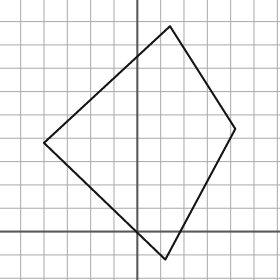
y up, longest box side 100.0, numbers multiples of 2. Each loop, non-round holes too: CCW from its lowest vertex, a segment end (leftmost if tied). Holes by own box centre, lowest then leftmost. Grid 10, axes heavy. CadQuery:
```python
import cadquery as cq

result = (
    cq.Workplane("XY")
    .moveTo(12.0, -12.0)
    .lineTo(42.0, 44.0)
    .lineTo(14.0, 88.0)
    .lineTo(-40.0, 38.0)
    .close()
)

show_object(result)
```